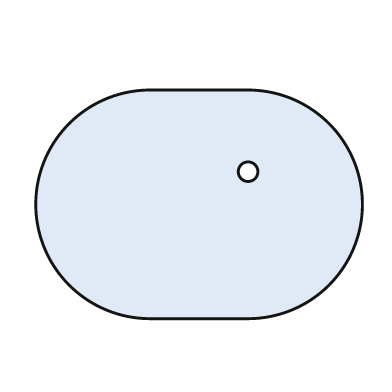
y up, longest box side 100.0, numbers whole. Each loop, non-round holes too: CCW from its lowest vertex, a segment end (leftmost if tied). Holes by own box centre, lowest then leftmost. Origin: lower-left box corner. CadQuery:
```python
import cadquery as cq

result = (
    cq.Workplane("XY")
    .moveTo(35.0, 0.0)
    .lineTo(65.0, 0.0)
    .threePointArc((100.0, 35.0), (65.0, 70.0))
    .lineTo(35.0, 70.0)
    .threePointArc((0.0, 35.0), (35.0, 0.0))
    .close()
    .moveTo(65.0, 45.0)
    .circle(3.0)
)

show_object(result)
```